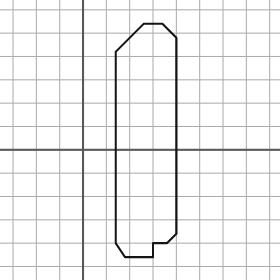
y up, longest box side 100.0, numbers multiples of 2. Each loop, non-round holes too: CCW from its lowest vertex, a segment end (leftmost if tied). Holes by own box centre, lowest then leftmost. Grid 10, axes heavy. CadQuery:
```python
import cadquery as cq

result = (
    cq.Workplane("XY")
    .moveTo(18.0, -46.0)
    .lineTo(30.0, -46.0)
    .lineTo(30.0, -40.0)
    .lineTo(36.0, -40.0)
    .lineTo(40.0, -36.0)
    .lineTo(40.0, 48.0)
    .lineTo(34.0, 54.0)
    .lineTo(26.0, 54.0)
    .lineTo(14.0, 42.0)
    .lineTo(14.0, -40.0)
    .close()
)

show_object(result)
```